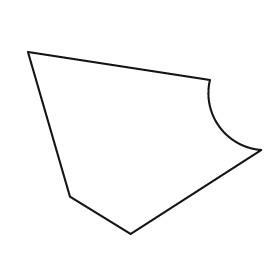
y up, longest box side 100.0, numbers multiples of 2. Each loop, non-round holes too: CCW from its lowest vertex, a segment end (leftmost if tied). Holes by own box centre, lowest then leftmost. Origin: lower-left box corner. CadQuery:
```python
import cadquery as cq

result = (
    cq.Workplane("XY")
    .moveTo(44.0, 0.0)
    .lineTo(100.0, 36.0)
    .threePointArc((82.0, 46.0), (78.0, 66.0))
    .lineTo(0.0, 78.0)
    .lineTo(18.0, 16.0)
    .close()
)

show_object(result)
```